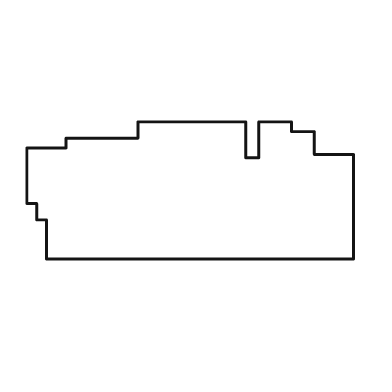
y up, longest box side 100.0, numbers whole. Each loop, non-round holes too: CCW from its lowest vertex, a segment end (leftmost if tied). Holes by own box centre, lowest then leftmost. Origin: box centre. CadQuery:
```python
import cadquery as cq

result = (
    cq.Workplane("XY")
    .moveTo(-44.0, -21.0)
    .lineTo(50.0, -21.0)
    .lineTo(50.0, 11.0)
    .lineTo(38.0, 11.0)
    .lineTo(38.0, 18.0)
    .lineTo(31.0, 18.0)
    .lineTo(31.0, 21.0)
    .lineTo(21.0, 21.0)
    .lineTo(21.0, 10.0)
    .lineTo(17.0, 10.0)
    .lineTo(17.0, 21.0)
    .lineTo(-16.0, 21.0)
    .lineTo(-16.0, 16.0)
    .lineTo(-38.0, 16.0)
    .lineTo(-38.0, 13.0)
    .lineTo(-50.0, 13.0)
    .lineTo(-50.0, -4.0)
    .lineTo(-47.0, -4.0)
    .lineTo(-47.0, -9.0)
    .lineTo(-44.0, -9.0)
    .close()
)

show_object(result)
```